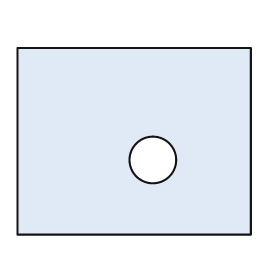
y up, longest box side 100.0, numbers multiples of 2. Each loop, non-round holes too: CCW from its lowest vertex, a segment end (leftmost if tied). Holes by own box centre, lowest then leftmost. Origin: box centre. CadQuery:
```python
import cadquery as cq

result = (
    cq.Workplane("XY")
    .moveTo(-50.0, -40.0)
    .lineTo(50.0, -40.0)
    .lineTo(50.0, 40.0)
    .lineTo(-50.0, 40.0)
    .close()
    .moveTo(8.0, -8.0)
    .circle(10.0)
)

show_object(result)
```